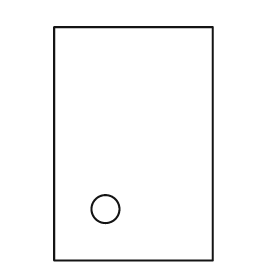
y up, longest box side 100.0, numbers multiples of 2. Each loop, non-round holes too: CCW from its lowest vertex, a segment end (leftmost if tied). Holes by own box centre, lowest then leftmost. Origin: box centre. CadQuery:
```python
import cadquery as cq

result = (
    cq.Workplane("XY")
    .moveTo(-34.0, -50.0)
    .lineTo(34.0, -50.0)
    .lineTo(34.0, 50.0)
    .lineTo(-34.0, 50.0)
    .close()
    .moveTo(-12.0, -28.0)
    .circle(6.0)
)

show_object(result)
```